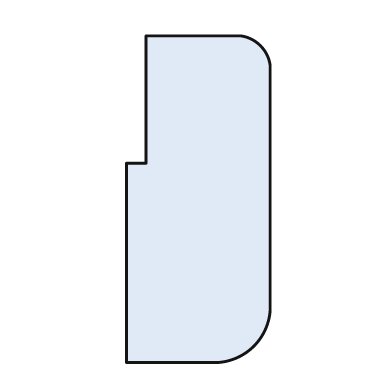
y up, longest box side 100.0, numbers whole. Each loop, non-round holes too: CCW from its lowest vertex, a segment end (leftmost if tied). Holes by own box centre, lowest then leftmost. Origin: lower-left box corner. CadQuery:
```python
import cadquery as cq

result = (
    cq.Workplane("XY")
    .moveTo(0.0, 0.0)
    .lineTo(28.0, 0.0)
    .threePointArc((39.0, 5.0), (44.0, 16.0))
    .lineTo(44.0, 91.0)
    .threePointArc((41.0, 97.0), (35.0, 100.0))
    .lineTo(6.0, 100.0)
    .lineTo(6.0, 61.0)
    .lineTo(0.0, 61.0)
    .close()
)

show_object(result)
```